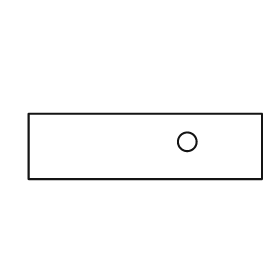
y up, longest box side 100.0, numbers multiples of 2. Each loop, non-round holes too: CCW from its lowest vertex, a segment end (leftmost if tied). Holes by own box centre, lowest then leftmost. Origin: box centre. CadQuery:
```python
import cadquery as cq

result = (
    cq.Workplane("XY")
    .moveTo(-50.0, -14.0)
    .lineTo(50.0, -14.0)
    .lineTo(50.0, 14.0)
    .lineTo(-50.0, 14.0)
    .close()
    .moveTo(18.0, 2.0)
    .circle(4.0)
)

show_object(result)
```